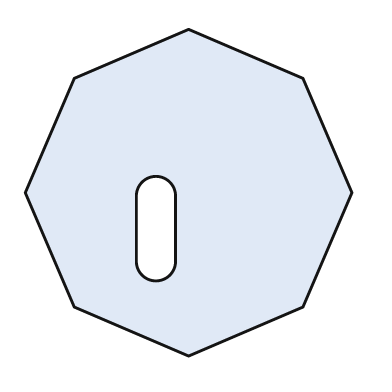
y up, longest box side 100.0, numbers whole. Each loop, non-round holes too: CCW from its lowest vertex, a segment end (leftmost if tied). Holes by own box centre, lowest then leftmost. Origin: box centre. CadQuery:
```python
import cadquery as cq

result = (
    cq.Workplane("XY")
    .moveTo(0.0, -50.0)
    .lineTo(35.0, -35.0)
    .lineTo(50.0, 0.0)
    .lineTo(35.0, 35.0)
    .lineTo(0.0, 50.0)
    .lineTo(-35.0, 35.0)
    .lineTo(-50.0, 0.0)
    .lineTo(-35.0, -35.0)
    .close()
    .moveTo(-16.0, -21.0)
    .threePointArc((-10.0, -27.0), (-4.0, -21.0))
    .lineTo(-4.0, -1.0)
    .threePointArc((-10.0, 5.0), (-16.0, -1.0))
    .close()
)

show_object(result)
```